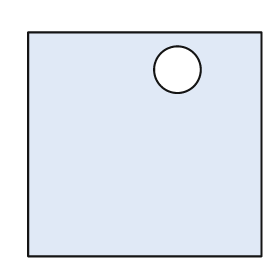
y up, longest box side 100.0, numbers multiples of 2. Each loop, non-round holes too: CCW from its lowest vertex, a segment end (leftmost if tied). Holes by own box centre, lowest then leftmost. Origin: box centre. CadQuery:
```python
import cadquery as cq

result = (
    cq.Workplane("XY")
    .moveTo(-50.0, -48.0)
    .lineTo(50.0, -48.0)
    .lineTo(50.0, 48.0)
    .lineTo(-50.0, 48.0)
    .close()
    .moveTo(14.0, 32.0)
    .circle(10.0)
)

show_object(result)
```